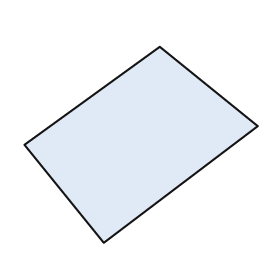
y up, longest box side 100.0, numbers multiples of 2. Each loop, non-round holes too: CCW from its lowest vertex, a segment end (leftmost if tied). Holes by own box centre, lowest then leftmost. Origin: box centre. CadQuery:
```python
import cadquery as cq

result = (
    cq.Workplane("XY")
    .moveTo(-16.0, -42.0)
    .lineTo(50.0, 8.0)
    .lineTo(8.0, 42.0)
    .lineTo(-50.0, 0.0)
    .close()
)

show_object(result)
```